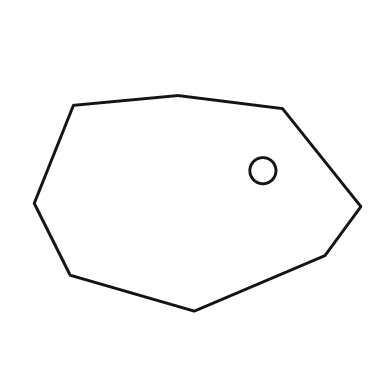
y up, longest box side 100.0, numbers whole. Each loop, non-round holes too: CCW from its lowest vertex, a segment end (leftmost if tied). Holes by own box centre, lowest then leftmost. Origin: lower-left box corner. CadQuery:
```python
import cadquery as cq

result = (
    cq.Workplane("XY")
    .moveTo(49.0, 0.0)
    .lineTo(89.0, 17.0)
    .lineTo(100.0, 32.0)
    .lineTo(76.0, 62.0)
    .lineTo(44.0, 66.0)
    .lineTo(12.0, 63.0)
    .lineTo(0.0, 33.0)
    .lineTo(11.0, 11.0)
    .close()
    .moveTo(70.0, 43.0)
    .circle(4.0)
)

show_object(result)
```